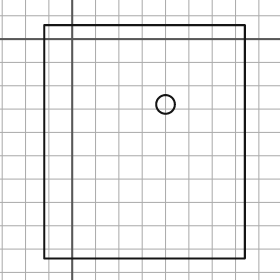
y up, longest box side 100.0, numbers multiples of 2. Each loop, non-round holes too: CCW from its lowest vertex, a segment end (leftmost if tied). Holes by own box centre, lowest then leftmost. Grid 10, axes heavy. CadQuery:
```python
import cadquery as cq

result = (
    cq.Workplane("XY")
    .moveTo(-12.0, -94.0)
    .lineTo(74.0, -94.0)
    .lineTo(74.0, 6.0)
    .lineTo(-12.0, 6.0)
    .close()
    .moveTo(40.0, -28.0)
    .circle(4.0)
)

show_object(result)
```